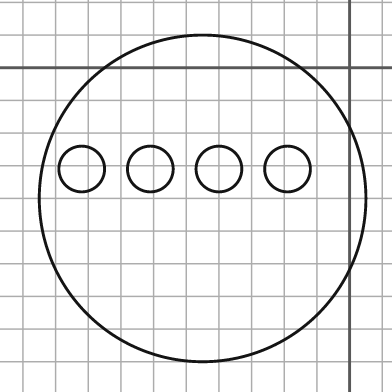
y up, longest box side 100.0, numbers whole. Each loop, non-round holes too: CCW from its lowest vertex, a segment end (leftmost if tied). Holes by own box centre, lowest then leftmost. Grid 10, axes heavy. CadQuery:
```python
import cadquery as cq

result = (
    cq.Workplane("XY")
    .moveTo(-45.0, -40.0)
    .circle(50.0)
    .moveTo(-82.0, -31.0)
    .circle(7.0)
    .moveTo(-61.0, -31.0)
    .circle(7.0)
    .moveTo(-40.0, -31.0)
    .circle(7.0)
    .moveTo(-19.0, -31.0)
    .circle(7.0)
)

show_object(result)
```